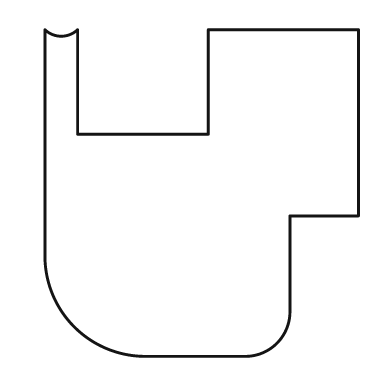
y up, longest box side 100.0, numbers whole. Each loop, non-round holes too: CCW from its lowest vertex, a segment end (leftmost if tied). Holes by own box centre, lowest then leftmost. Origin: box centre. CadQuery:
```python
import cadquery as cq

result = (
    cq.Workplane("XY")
    .moveTo(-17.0, -50.0)
    .lineTo(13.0, -50.0)
    .threePointArc((23.0, -46.0), (27.0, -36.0))
    .lineTo(27.0, -7.0)
    .lineTo(48.0, -7.0)
    .lineTo(48.0, 50.0)
    .lineTo(2.0, 50.0)
    .lineTo(2.0, 18.0)
    .lineTo(-38.0, 18.0)
    .lineTo(-38.0, 50.0)
    .threePointArc((-43.0, 48.0), (-48.0, 50.0))
    .lineTo(-48.0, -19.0)
    .threePointArc((-39.0, -41.0), (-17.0, -50.0))
    .close()
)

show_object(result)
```